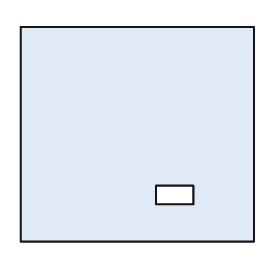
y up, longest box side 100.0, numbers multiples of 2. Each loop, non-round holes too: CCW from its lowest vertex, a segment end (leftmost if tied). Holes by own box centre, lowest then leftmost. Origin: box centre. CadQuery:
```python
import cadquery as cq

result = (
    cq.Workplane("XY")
    .moveTo(-50.0, -46.0)
    .lineTo(50.0, -46.0)
    .lineTo(50.0, 46.0)
    .lineTo(-50.0, 46.0)
    .close()
    .moveTo(8.0, -30.0)
    .lineTo(24.0, -30.0)
    .lineTo(24.0, -22.0)
    .lineTo(8.0, -22.0)
    .close()
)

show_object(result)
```